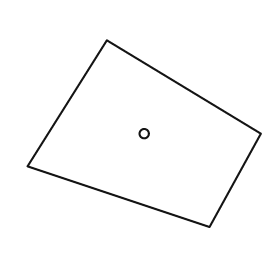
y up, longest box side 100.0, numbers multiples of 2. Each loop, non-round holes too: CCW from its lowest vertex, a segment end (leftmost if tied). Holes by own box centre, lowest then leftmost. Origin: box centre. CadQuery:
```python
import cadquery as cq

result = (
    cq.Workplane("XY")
    .moveTo(28.0, -40.0)
    .lineTo(50.0, 0.0)
    .lineTo(-16.0, 40.0)
    .lineTo(-50.0, -14.0)
    .close()
    .moveTo(0.0, 0.0)
    .circle(2.0)
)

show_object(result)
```